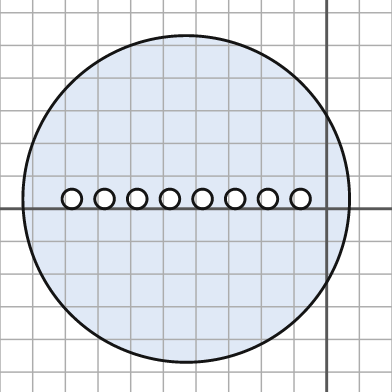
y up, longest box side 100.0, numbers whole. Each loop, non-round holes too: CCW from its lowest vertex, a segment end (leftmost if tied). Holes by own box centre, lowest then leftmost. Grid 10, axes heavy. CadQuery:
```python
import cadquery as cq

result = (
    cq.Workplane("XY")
    .moveTo(-43.0, 3.0)
    .circle(50.0)
    .moveTo(-78.0, 3.0)
    .circle(3.0)
    .moveTo(-68.0, 3.0)
    .circle(3.0)
    .moveTo(-58.0, 3.0)
    .circle(3.0)
    .moveTo(-48.0, 3.0)
    .circle(3.0)
    .moveTo(-38.0, 3.0)
    .circle(3.0)
    .moveTo(-28.0, 3.0)
    .circle(3.0)
    .moveTo(-18.0, 3.0)
    .circle(3.0)
    .moveTo(-8.0, 3.0)
    .circle(3.0)
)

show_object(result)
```